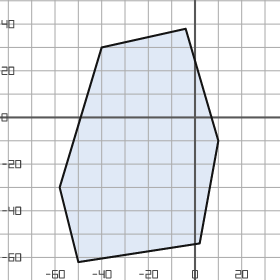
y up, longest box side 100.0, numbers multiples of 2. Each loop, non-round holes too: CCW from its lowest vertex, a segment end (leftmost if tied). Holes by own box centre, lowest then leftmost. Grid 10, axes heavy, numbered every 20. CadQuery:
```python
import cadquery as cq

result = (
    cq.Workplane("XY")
    .moveTo(-50.0, -62.0)
    .lineTo(2.0, -54.0)
    .lineTo(10.0, -10.0)
    .lineTo(-4.0, 38.0)
    .lineTo(-40.0, 30.0)
    .lineTo(-58.0, -30.0)
    .close()
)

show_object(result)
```